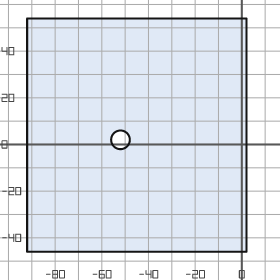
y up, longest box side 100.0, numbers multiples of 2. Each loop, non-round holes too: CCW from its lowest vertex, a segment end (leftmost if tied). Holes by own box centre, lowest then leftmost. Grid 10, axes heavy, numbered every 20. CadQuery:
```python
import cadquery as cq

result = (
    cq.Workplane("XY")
    .moveTo(-92.0, -46.0)
    .lineTo(2.0, -46.0)
    .lineTo(2.0, 54.0)
    .lineTo(-92.0, 54.0)
    .close()
    .moveTo(-52.0, 2.0)
    .circle(4.0)
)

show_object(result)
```